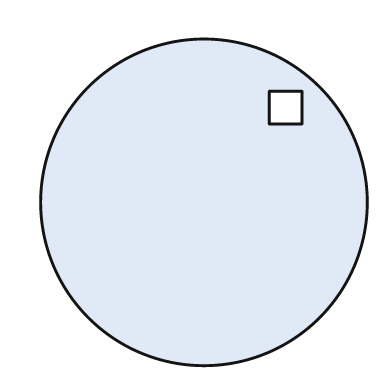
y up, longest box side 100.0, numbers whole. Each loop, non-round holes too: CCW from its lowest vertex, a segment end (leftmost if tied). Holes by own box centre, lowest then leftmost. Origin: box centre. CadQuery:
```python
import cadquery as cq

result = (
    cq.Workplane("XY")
    .moveTo(0.0, 0.0)
    .circle(50.0)
    .moveTo(20.0, 24.0)
    .lineTo(30.0, 24.0)
    .lineTo(30.0, 34.0)
    .lineTo(20.0, 34.0)
    .close()
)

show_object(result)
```